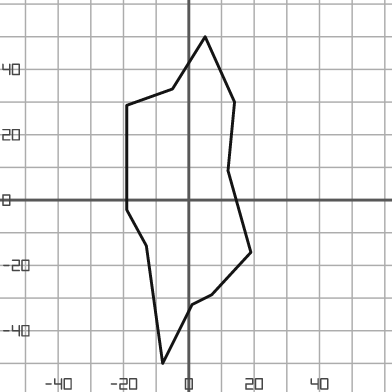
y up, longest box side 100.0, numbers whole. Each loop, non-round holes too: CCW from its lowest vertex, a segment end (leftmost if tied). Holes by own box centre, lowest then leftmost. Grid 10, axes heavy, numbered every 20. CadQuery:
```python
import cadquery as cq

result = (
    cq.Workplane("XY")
    .moveTo(-8.0, -50.0)
    .lineTo(1.0, -32.0)
    .lineTo(7.0, -29.0)
    .lineTo(19.0, -16.0)
    .lineTo(12.0, 9.0)
    .lineTo(14.0, 30.0)
    .lineTo(5.0, 50.0)
    .lineTo(-5.0, 34.0)
    .lineTo(-19.0, 29.0)
    .lineTo(-19.0, -3.0)
    .lineTo(-13.0, -14.0)
    .close()
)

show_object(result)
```